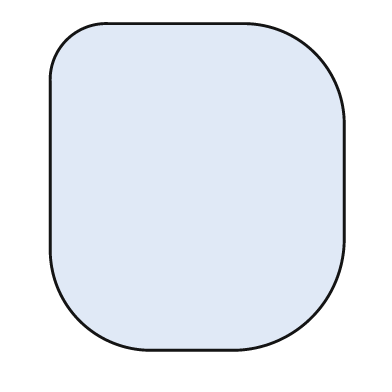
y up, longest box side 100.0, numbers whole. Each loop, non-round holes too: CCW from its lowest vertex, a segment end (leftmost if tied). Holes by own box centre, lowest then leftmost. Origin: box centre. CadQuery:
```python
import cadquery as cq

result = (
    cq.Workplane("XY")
    .moveTo(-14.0, -50.0)
    .lineTo(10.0, -50.0)
    .threePointArc((35.0, -40.0), (45.0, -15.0))
    .lineTo(45.0, 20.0)
    .threePointArc((36.0, 41.0), (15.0, 50.0))
    .lineTo(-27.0, 50.0)
    .threePointArc((-40.0, 45.0), (-45.0, 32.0))
    .lineTo(-45.0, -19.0)
    .threePointArc((-36.0, -41.0), (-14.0, -50.0))
    .close()
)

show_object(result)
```